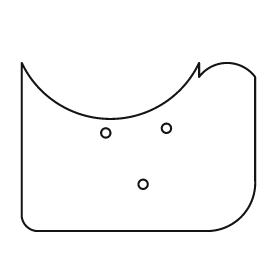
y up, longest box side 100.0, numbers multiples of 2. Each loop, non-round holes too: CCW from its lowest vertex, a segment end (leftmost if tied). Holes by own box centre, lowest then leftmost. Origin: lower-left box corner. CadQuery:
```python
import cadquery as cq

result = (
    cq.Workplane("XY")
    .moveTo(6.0, 0.0)
    .lineTo(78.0, 0.0)
    .threePointArc((94.0, 6.0), (100.0, 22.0))
    .lineTo(100.0, 66.0)
    .threePointArc((88.0, 72.0), (76.0, 66.0))
    .lineTo(76.0, 72.0)
    .threePointArc((38.0, 48.0), (0.0, 72.0))
    .lineTo(0.0, 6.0)
    .threePointArc((2.0, 2.0), (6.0, 0.0))
    .close()
    .moveTo(52.0, 20.0)
    .circle(2.0)
    .moveTo(36.0, 42.0)
    .circle(2.0)
    .moveTo(62.0, 44.0)
    .circle(2.0)
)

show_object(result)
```